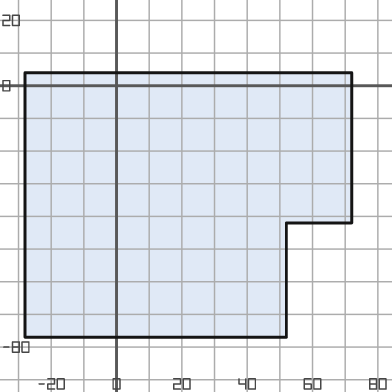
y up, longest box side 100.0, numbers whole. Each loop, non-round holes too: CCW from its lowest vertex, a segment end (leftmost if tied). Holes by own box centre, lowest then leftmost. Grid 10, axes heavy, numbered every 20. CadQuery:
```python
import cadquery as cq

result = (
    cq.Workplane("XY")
    .moveTo(-28.0, -77.0)
    .lineTo(52.0, -77.0)
    .lineTo(52.0, -42.0)
    .lineTo(72.0, -42.0)
    .lineTo(72.0, 4.0)
    .lineTo(-28.0, 4.0)
    .close()
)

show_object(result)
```